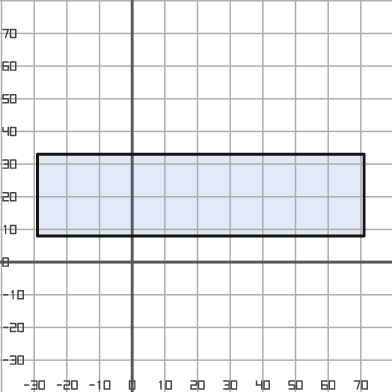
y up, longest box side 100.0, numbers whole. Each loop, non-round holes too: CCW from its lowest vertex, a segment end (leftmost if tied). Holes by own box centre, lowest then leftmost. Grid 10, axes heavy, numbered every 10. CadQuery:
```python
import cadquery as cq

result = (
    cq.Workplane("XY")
    .moveTo(-29.0, 8.0)
    .lineTo(71.0, 8.0)
    .lineTo(71.0, 33.0)
    .lineTo(-29.0, 33.0)
    .close()
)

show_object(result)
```